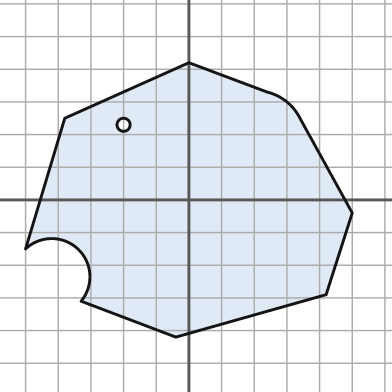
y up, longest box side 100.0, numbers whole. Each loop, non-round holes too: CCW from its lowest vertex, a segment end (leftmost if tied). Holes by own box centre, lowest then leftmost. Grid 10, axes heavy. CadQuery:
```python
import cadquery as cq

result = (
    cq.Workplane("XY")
    .moveTo(-4.0, -42.0)
    .lineTo(42.0, -29.0)
    .lineTo(50.0, -4.0)
    .lineTo(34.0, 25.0)
    .threePointArc((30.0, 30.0), (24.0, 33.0))
    .lineTo(0.0, 42.0)
    .lineTo(-38.0, 25.0)
    .lineTo(-50.0, -15.0)
    .threePointArc((-34.0, -15.0), (-33.0, -31.0))
    .close()
    .moveTo(-20.0, 23.0)
    .circle(2.0)
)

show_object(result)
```